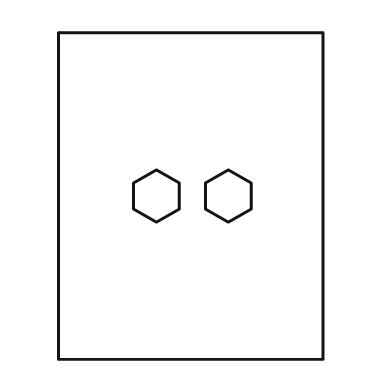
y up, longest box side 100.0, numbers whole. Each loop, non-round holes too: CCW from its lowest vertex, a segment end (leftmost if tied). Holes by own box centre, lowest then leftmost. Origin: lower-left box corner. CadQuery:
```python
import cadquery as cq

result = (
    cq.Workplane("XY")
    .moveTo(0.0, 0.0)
    .lineTo(81.0, 0.0)
    .lineTo(81.0, 100.0)
    .lineTo(0.0, 100.0)
    .close()
    .moveTo(30.0, 42.0)
    .lineTo(37.0, 46.0)
    .lineTo(37.0, 54.0)
    .lineTo(30.0, 58.0)
    .lineTo(23.0, 54.0)
    .lineTo(23.0, 46.0)
    .close()
    .moveTo(52.0, 42.0)
    .lineTo(59.0, 46.0)
    .lineTo(59.0, 54.0)
    .lineTo(52.0, 58.0)
    .lineTo(45.0, 54.0)
    .lineTo(45.0, 46.0)
    .close()
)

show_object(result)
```